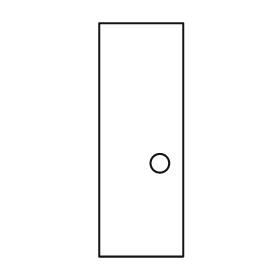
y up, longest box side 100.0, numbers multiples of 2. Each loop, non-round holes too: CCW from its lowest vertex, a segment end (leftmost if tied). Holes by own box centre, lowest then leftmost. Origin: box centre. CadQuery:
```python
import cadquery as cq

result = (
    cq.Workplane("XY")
    .moveTo(-18.0, -50.0)
    .lineTo(18.0, -50.0)
    .lineTo(18.0, 50.0)
    .lineTo(-18.0, 50.0)
    .close()
    .moveTo(8.0, -10.0)
    .circle(4.0)
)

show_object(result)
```